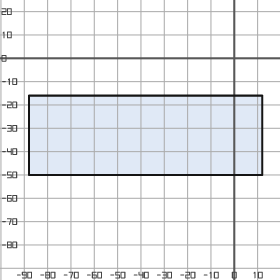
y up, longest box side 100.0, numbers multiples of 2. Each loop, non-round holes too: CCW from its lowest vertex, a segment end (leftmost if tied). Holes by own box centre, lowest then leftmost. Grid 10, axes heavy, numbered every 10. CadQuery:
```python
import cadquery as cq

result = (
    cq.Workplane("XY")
    .moveTo(-88.0, -50.0)
    .lineTo(12.0, -50.0)
    .lineTo(12.0, -16.0)
    .lineTo(-88.0, -16.0)
    .close()
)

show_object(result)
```